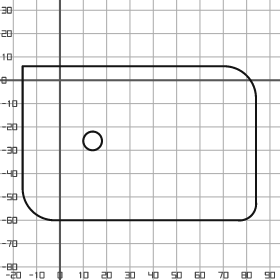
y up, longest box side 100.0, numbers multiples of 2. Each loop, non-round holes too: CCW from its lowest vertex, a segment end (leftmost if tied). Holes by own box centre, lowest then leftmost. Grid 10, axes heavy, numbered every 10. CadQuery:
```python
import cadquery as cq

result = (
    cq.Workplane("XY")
    .moveTo(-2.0, -60.0)
    .lineTo(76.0, -60.0)
    .threePointArc((82.0, -58.0), (84.0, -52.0))
    .lineTo(84.0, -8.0)
    .threePointArc((80.0, 2.0), (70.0, 6.0))
    .lineTo(-16.0, 6.0)
    .lineTo(-16.0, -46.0)
    .threePointArc((-12.0, -56.0), (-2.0, -60.0))
    .close()
    .moveTo(14.0, -26.0)
    .circle(4.0)
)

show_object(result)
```